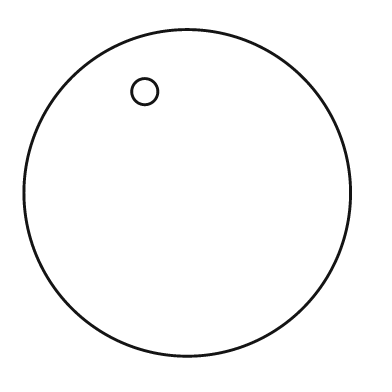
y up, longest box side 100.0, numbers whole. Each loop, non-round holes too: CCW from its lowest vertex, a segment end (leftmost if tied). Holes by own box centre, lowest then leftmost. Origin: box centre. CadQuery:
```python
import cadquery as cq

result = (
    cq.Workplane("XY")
    .moveTo(0.0, 0.0)
    .circle(50.0)
    .moveTo(-13.0, 31.0)
    .circle(4.0)
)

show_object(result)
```